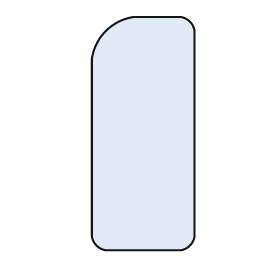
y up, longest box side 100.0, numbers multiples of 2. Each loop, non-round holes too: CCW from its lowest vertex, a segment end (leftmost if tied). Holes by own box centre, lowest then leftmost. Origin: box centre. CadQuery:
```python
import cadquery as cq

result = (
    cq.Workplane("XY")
    .moveTo(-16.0, -50.0)
    .lineTo(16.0, -50.0)
    .threePointArc((20.0, -48.0), (22.0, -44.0))
    .lineTo(22.0, 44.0)
    .threePointArc((20.0, 48.0), (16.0, 50.0))
    .lineTo(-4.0, 50.0)
    .threePointArc((-16.0, 44.0), (-22.0, 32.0))
    .lineTo(-22.0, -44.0)
    .threePointArc((-20.0, -48.0), (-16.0, -50.0))
    .close()
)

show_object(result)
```